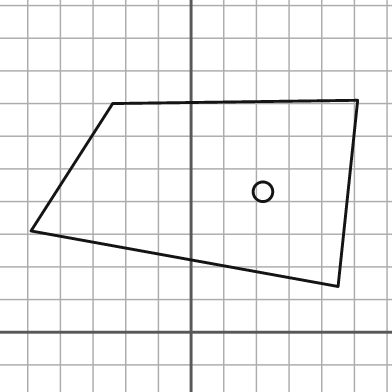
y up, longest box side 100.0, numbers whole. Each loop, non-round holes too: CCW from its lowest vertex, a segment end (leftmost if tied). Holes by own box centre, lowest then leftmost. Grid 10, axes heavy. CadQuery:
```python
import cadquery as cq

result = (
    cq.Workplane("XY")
    .moveTo(45.0, 14.0)
    .lineTo(51.0, 71.0)
    .lineTo(-24.0, 70.0)
    .lineTo(-49.0, 31.0)
    .close()
    .moveTo(22.0, 43.0)
    .circle(3.0)
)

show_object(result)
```